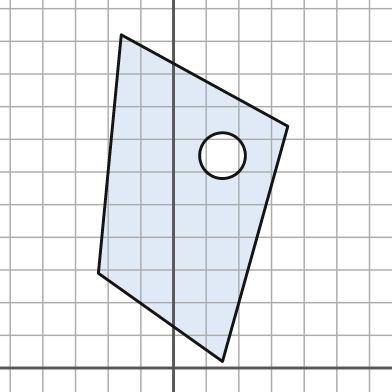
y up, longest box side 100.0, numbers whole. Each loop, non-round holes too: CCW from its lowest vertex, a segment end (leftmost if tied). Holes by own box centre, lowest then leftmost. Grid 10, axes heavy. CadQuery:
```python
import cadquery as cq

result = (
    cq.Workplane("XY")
    .moveTo(15.0, 2.0)
    .lineTo(35.0, 74.0)
    .lineTo(-16.0, 102.0)
    .lineTo(-23.0, 29.0)
    .close()
    .moveTo(15.0, 65.0)
    .circle(7.0)
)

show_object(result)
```